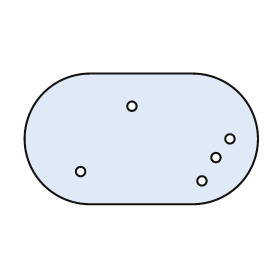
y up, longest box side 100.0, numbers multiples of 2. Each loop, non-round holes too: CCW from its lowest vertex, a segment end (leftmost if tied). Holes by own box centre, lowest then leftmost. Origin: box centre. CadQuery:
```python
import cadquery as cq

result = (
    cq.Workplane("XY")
    .moveTo(-22.0, -28.0)
    .lineTo(22.0, -28.0)
    .threePointArc((50.0, 0.0), (22.0, 28.0))
    .lineTo(-22.0, 28.0)
    .threePointArc((-50.0, 0.0), (-22.0, -28.0))
    .close()
    .moveTo(26.0, -18.0)
    .circle(2.0)
    .moveTo(-26.0, -14.0)
    .circle(2.0)
    .moveTo(32.0, -8.0)
    .circle(2.0)
    .moveTo(38.0, 0.0)
    .circle(2.0)
    .moveTo(-4.0, 14.0)
    .circle(2.0)
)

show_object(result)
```